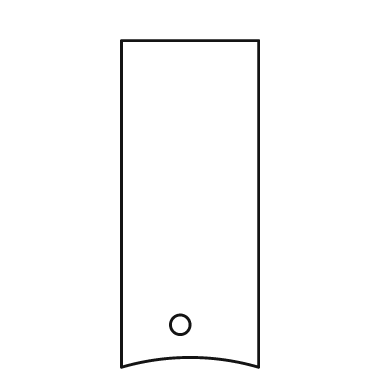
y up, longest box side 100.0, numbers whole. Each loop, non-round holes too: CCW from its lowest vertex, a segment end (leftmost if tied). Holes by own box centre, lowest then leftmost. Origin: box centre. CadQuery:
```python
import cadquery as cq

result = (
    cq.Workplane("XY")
    .moveTo(-21.0, -50.0)
    .threePointArc((0.0, -47.0), (21.0, -50.0))
    .lineTo(21.0, 50.0)
    .lineTo(-21.0, 50.0)
    .close()
    .moveTo(-3.0, -37.0)
    .circle(3.0)
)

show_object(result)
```